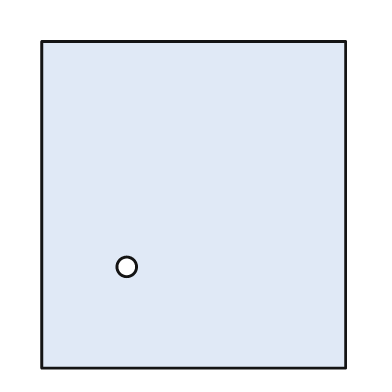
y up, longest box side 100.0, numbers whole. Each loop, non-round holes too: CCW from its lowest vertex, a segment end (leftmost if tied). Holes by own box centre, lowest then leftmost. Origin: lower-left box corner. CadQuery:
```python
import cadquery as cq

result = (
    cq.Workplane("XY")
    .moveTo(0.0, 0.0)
    .lineTo(93.0, 0.0)
    .lineTo(93.0, 100.0)
    .lineTo(0.0, 100.0)
    .close()
    .moveTo(26.0, 31.0)
    .circle(3.0)
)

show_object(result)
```